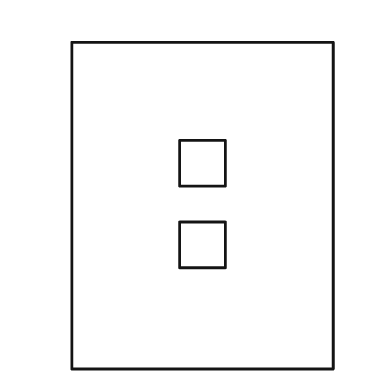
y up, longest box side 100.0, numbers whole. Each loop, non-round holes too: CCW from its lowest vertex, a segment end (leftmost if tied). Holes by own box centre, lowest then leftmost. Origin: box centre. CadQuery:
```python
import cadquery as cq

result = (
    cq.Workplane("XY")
    .moveTo(-40.0, -50.0)
    .lineTo(40.0, -50.0)
    .lineTo(40.0, 50.0)
    .lineTo(-40.0, 50.0)
    .close()
    .moveTo(-7.0, -19.0)
    .lineTo(7.0, -19.0)
    .lineTo(7.0, -5.0)
    .lineTo(-7.0, -5.0)
    .close()
    .moveTo(-7.0, 6.0)
    .lineTo(7.0, 6.0)
    .lineTo(7.0, 20.0)
    .lineTo(-7.0, 20.0)
    .close()
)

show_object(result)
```